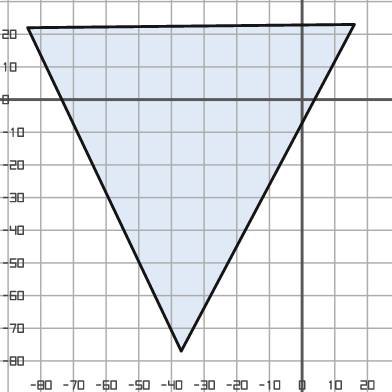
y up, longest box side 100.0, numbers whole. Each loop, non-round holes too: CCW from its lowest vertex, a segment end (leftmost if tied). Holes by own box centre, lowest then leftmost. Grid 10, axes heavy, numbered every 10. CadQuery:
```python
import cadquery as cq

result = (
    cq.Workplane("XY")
    .moveTo(-37.0, -77.0)
    .lineTo(16.0, 23.0)
    .lineTo(-84.0, 22.0)
    .close()
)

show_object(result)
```